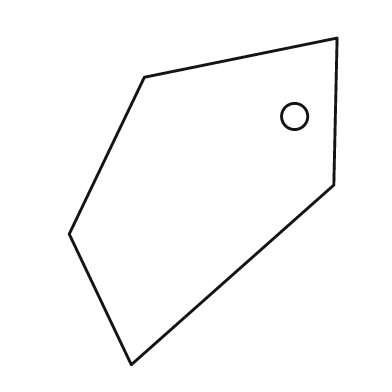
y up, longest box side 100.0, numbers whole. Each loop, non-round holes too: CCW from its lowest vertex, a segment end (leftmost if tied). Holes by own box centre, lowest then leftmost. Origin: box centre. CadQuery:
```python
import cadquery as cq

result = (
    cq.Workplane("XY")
    .moveTo(-22.0, -50.0)
    .lineTo(40.0, 5.0)
    .lineTo(41.0, 50.0)
    .lineTo(-18.0, 38.0)
    .lineTo(-41.0, -10.0)
    .close()
    .moveTo(28.0, 26.0)
    .circle(4.0)
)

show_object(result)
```